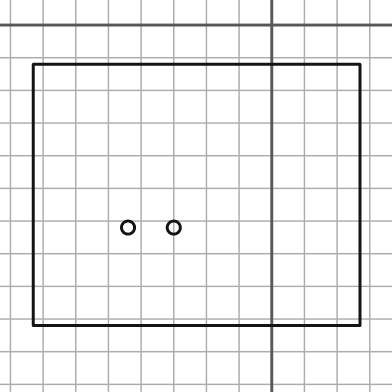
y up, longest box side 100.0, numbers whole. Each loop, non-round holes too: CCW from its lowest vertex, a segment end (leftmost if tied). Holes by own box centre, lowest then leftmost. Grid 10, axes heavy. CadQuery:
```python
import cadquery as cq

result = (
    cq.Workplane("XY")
    .moveTo(-73.0, -92.0)
    .lineTo(27.0, -92.0)
    .lineTo(27.0, -12.0)
    .lineTo(-73.0, -12.0)
    .close()
    .moveTo(-44.0, -62.0)
    .circle(2.0)
    .moveTo(-30.0, -62.0)
    .circle(2.0)
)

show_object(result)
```